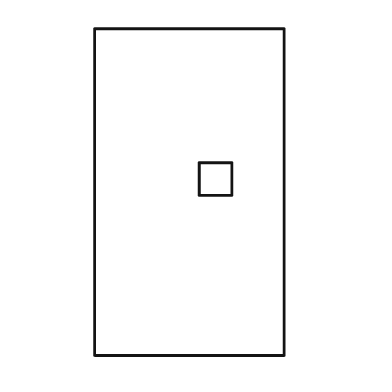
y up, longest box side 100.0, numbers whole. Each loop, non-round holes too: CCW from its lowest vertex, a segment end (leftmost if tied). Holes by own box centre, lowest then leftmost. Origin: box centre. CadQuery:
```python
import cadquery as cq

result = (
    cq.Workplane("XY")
    .moveTo(-29.0, -50.0)
    .lineTo(29.0, -50.0)
    .lineTo(29.0, 50.0)
    .lineTo(-29.0, 50.0)
    .close()
    .moveTo(3.0, -1.0)
    .lineTo(13.0, -1.0)
    .lineTo(13.0, 9.0)
    .lineTo(3.0, 9.0)
    .close()
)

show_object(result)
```